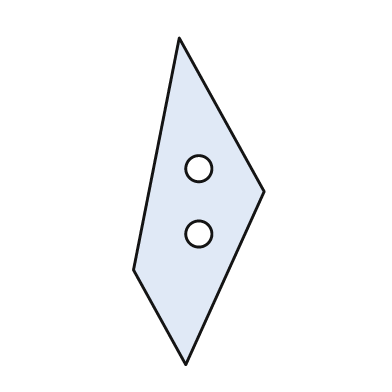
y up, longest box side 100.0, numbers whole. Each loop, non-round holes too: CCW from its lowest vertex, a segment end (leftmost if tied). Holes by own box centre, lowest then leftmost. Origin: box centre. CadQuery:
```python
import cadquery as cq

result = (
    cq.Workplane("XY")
    .moveTo(-4.0, -50.0)
    .lineTo(20.0, 3.0)
    .lineTo(-6.0, 50.0)
    .lineTo(-20.0, -21.0)
    .close()
    .moveTo(0.0, -10.0)
    .circle(4.0)
    .moveTo(0.0, 10.0)
    .circle(4.0)
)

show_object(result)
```